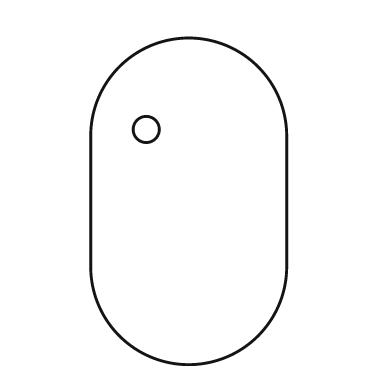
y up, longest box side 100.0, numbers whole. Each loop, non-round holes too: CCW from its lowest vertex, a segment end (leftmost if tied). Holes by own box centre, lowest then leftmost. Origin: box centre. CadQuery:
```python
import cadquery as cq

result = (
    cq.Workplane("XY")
    .moveTo(-30.0, -20.0)
    .threePointArc((0.0, -50.0), (30.0, -20.0))
    .lineTo(30.0, 20.0)
    .threePointArc((0.0, 50.0), (-30.0, 20.0))
    .close()
    .moveTo(-13.0, 22.0)
    .circle(4.0)
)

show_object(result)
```